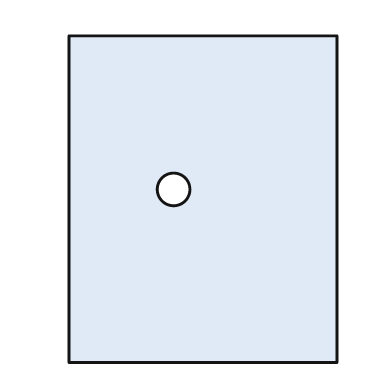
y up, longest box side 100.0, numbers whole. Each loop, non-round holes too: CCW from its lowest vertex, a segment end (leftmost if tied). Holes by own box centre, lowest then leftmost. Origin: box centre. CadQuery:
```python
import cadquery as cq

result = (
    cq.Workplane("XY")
    .moveTo(-41.0, -50.0)
    .lineTo(41.0, -50.0)
    .lineTo(41.0, 50.0)
    .lineTo(-41.0, 50.0)
    .close()
    .moveTo(-9.0, 3.0)
    .circle(5.0)
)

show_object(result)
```